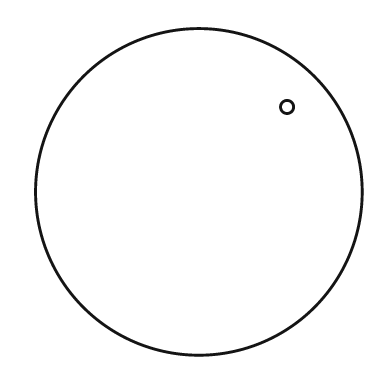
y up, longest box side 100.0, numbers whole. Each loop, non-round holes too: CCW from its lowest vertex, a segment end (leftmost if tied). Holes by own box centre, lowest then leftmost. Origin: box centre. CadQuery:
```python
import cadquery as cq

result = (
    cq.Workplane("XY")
    .moveTo(0.0, 0.0)
    .circle(50.0)
    .moveTo(27.0, 26.0)
    .circle(2.0)
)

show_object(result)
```